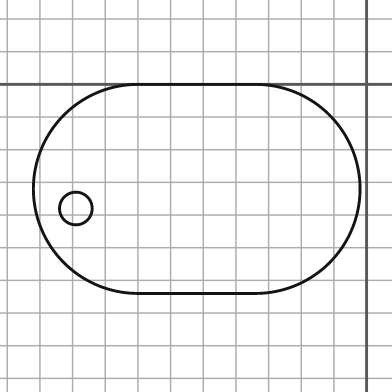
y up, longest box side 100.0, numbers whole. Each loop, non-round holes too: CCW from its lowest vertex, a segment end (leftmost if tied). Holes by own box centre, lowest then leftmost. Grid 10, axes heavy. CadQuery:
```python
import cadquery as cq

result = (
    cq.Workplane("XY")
    .moveTo(-70.0, -64.0)
    .lineTo(-34.0, -64.0)
    .threePointArc((-2.0, -32.0), (-34.0, 0.0))
    .lineTo(-70.0, 0.0)
    .threePointArc((-102.0, -32.0), (-70.0, -64.0))
    .close()
    .moveTo(-89.0, -38.0)
    .circle(5.0)
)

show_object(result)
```